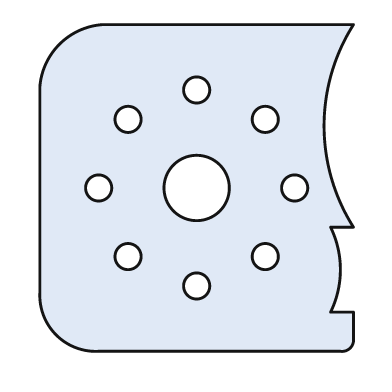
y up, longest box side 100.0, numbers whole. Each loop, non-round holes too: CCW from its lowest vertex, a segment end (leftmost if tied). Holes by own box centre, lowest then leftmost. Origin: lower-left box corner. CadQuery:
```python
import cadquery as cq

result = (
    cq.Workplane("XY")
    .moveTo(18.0, 0.0)
    .lineTo(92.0, 0.0)
    .threePointArc((95.0, 1.0), (96.0, 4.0))
    .lineTo(96.0, 12.0)
    .lineTo(89.0, 12.0)
    .threePointArc((92.0, 25.0), (89.0, 38.0))
    .lineTo(96.0, 38.0)
    .threePointArc((87.0, 69.0), (96.0, 100.0))
    .lineTo(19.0, 100.0)
    .threePointArc((6.0, 94.0), (0.0, 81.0))
    .lineTo(0.0, 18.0)
    .threePointArc((5.0, 5.0), (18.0, 0.0))
    .close()
    .moveTo(48.0, 20.0)
    .circle(4.0)
    .moveTo(27.0, 29.0)
    .circle(4.0)
    .moveTo(69.0, 29.0)
    .circle(4.0)
    .moveTo(18.0, 50.0)
    .circle(4.0)
    .moveTo(48.0, 50.0)
    .circle(10.0)
    .moveTo(78.0, 50.0)
    .circle(4.0)
    .moveTo(27.0, 71.0)
    .circle(4.0)
    .moveTo(69.0, 71.0)
    .circle(4.0)
    .moveTo(48.0, 80.0)
    .circle(4.0)
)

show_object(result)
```